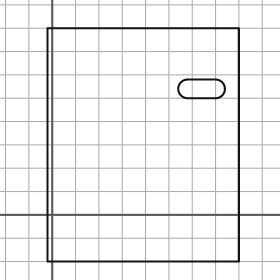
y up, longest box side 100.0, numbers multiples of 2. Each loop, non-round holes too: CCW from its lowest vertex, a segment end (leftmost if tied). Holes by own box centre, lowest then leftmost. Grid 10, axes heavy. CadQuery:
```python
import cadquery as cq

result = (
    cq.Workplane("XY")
    .moveTo(-2.0, -20.0)
    .lineTo(80.0, -20.0)
    .lineTo(80.0, 80.0)
    .lineTo(-2.0, 80.0)
    .close()
    .moveTo(58.0, 50.0)
    .lineTo(70.0, 50.0)
    .threePointArc((74.0, 54.0), (70.0, 58.0))
    .lineTo(58.0, 58.0)
    .threePointArc((54.0, 54.0), (58.0, 50.0))
    .close()
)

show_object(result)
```